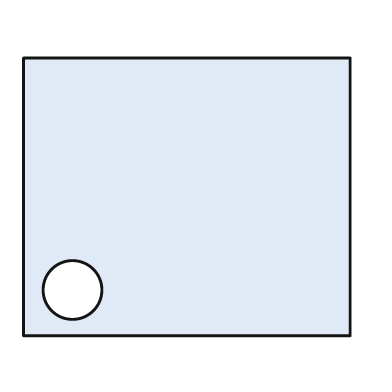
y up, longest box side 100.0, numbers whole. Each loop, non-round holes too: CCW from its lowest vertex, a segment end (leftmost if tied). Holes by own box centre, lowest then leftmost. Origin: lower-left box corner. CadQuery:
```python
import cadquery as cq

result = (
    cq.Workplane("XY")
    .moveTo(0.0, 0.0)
    .lineTo(100.0, 0.0)
    .lineTo(100.0, 85.0)
    .lineTo(0.0, 85.0)
    .close()
    .moveTo(15.0, 14.0)
    .circle(9.0)
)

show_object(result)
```